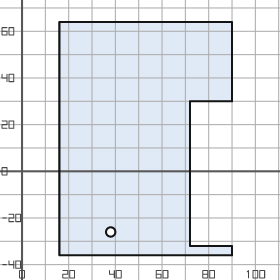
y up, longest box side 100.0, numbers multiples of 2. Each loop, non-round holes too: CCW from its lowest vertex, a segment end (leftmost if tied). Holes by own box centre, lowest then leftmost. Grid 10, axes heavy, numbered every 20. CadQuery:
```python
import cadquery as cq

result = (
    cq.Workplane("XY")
    .moveTo(16.0, -36.0)
    .lineTo(90.0, -36.0)
    .lineTo(90.0, -32.0)
    .lineTo(72.0, -32.0)
    .lineTo(72.0, 30.0)
    .lineTo(90.0, 30.0)
    .lineTo(90.0, 64.0)
    .lineTo(16.0, 64.0)
    .close()
    .moveTo(38.0, -26.0)
    .circle(2.0)
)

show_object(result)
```